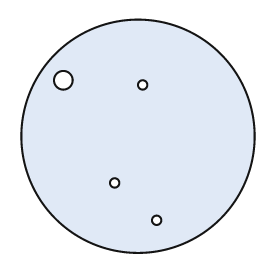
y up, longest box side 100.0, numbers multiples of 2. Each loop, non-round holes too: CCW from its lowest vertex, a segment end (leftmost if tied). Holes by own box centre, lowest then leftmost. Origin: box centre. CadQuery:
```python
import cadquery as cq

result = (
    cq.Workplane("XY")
    .moveTo(0.0, 0.0)
    .circle(50.0)
    .moveTo(8.0, -36.0)
    .circle(2.0)
    .moveTo(-10.0, -20.0)
    .circle(2.0)
    .moveTo(2.0, 22.0)
    .circle(2.0)
    .moveTo(-32.0, 24.0)
    .circle(4.0)
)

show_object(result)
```